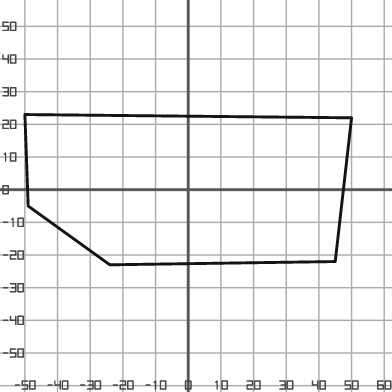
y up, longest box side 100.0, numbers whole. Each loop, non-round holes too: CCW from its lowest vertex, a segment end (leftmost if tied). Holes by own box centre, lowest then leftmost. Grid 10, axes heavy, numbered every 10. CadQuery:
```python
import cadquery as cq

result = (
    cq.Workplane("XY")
    .moveTo(-24.0, -23.0)
    .lineTo(45.0, -22.0)
    .lineTo(50.0, 22.0)
    .lineTo(-50.0, 23.0)
    .lineTo(-49.0, -5.0)
    .close()
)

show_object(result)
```